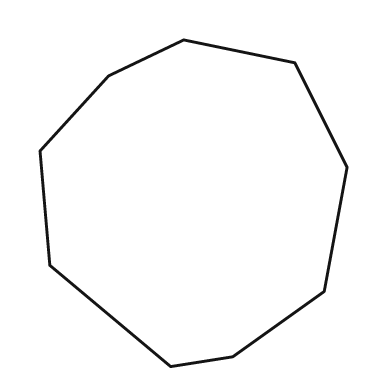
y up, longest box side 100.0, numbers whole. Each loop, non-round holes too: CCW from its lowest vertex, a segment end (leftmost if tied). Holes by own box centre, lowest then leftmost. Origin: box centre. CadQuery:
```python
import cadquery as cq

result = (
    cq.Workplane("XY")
    .moveTo(-7.0, -50.0)
    .lineTo(12.0, -47.0)
    .lineTo(40.0, -27.0)
    .lineTo(47.0, 11.0)
    .lineTo(31.0, 43.0)
    .lineTo(-3.0, 50.0)
    .lineTo(-26.0, 39.0)
    .lineTo(-47.0, 16.0)
    .lineTo(-44.0, -19.0)
    .close()
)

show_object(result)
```